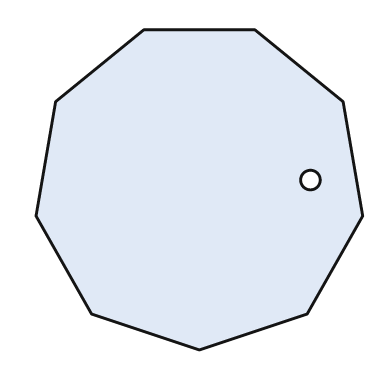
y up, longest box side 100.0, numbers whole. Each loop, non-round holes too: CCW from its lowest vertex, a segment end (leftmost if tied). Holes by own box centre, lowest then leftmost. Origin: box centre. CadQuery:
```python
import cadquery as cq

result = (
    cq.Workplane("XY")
    .moveTo(0.0, -49.0)
    .lineTo(33.0, -38.0)
    .lineTo(50.0, -8.0)
    .lineTo(44.0, 27.0)
    .lineTo(17.0, 49.0)
    .lineTo(-17.0, 49.0)
    .lineTo(-44.0, 27.0)
    .lineTo(-50.0, -8.0)
    .lineTo(-33.0, -38.0)
    .close()
    .moveTo(34.0, 3.0)
    .circle(3.0)
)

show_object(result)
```